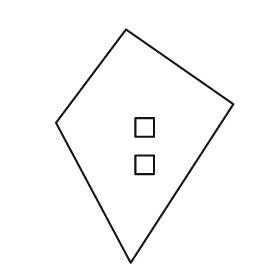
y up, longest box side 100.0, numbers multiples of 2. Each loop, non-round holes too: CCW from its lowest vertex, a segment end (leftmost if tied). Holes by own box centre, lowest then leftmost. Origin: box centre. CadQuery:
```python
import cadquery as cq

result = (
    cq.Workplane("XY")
    .moveTo(-6.0, -50.0)
    .lineTo(38.0, 18.0)
    .lineTo(-8.0, 50.0)
    .lineTo(-38.0, 10.0)
    .close()
    .moveTo(-4.0, -12.0)
    .lineTo(4.0, -12.0)
    .lineTo(4.0, -4.0)
    .lineTo(-4.0, -4.0)
    .close()
    .moveTo(-4.0, 4.0)
    .lineTo(4.0, 4.0)
    .lineTo(4.0, 12.0)
    .lineTo(-4.0, 12.0)
    .close()
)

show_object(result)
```